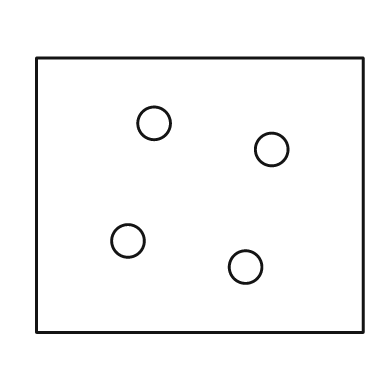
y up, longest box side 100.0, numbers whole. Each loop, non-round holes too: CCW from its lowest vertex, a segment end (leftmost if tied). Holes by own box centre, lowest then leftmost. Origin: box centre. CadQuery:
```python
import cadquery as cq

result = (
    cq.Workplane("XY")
    .moveTo(-50.0, -42.0)
    .lineTo(50.0, -42.0)
    .lineTo(50.0, 42.0)
    .lineTo(-50.0, 42.0)
    .close()
    .moveTo(14.0, -22.0)
    .circle(5.0)
    .moveTo(-22.0, -14.0)
    .circle(5.0)
    .moveTo(22.0, 14.0)
    .circle(5.0)
    .moveTo(-14.0, 22.0)
    .circle(5.0)
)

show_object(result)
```